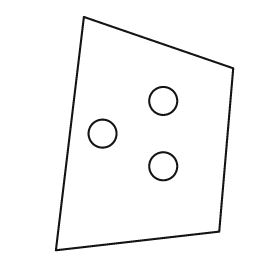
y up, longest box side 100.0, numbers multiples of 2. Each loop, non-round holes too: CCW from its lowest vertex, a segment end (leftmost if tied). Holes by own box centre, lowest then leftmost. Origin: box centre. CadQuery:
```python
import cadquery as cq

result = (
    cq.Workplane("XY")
    .moveTo(-38.0, -50.0)
    .lineTo(32.0, -42.0)
    .lineTo(38.0, 28.0)
    .lineTo(-26.0, 50.0)
    .close()
    .moveTo(8.0, -14.0)
    .circle(6.0)
    .moveTo(-18.0, 0.0)
    .circle(6.0)
    .moveTo(8.0, 14.0)
    .circle(6.0)
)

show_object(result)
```